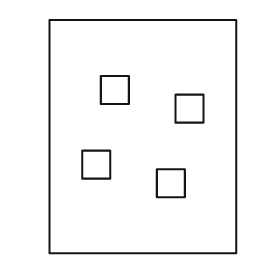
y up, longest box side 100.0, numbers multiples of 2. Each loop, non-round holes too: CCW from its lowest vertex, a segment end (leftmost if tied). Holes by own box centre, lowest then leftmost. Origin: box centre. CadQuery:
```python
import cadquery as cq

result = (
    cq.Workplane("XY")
    .moveTo(-40.0, -50.0)
    .lineTo(40.0, -50.0)
    .lineTo(40.0, 50.0)
    .lineTo(-40.0, 50.0)
    .close()
    .moveTo(6.0, -26.0)
    .lineTo(18.0, -26.0)
    .lineTo(18.0, -14.0)
    .lineTo(6.0, -14.0)
    .close()
    .moveTo(-26.0, -18.0)
    .lineTo(-14.0, -18.0)
    .lineTo(-14.0, -6.0)
    .lineTo(-26.0, -6.0)
    .close()
    .moveTo(14.0, 6.0)
    .lineTo(26.0, 6.0)
    .lineTo(26.0, 18.0)
    .lineTo(14.0, 18.0)
    .close()
    .moveTo(-18.0, 14.0)
    .lineTo(-6.0, 14.0)
    .lineTo(-6.0, 26.0)
    .lineTo(-18.0, 26.0)
    .close()
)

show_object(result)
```